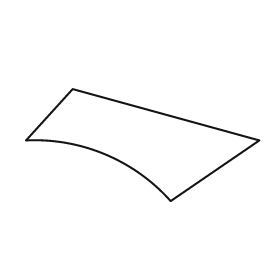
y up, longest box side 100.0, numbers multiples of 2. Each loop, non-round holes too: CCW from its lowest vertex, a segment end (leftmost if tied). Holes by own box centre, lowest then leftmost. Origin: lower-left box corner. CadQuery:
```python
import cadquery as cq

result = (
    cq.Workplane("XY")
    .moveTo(62.0, 0.0)
    .lineTo(100.0, 26.0)
    .lineTo(20.0, 48.0)
    .lineTo(0.0, 26.0)
    .threePointArc((34.0, 20.0), (62.0, 0.0))
    .close()
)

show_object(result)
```